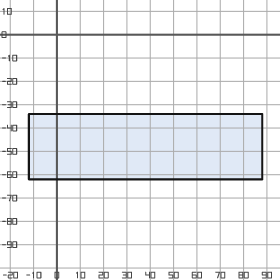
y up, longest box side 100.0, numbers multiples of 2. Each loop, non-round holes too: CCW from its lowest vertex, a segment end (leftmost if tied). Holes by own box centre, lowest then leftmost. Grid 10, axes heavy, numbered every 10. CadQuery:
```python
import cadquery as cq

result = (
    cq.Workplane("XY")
    .moveTo(-12.0, -62.0)
    .lineTo(88.0, -62.0)
    .lineTo(88.0, -34.0)
    .lineTo(-12.0, -34.0)
    .close()
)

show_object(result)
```